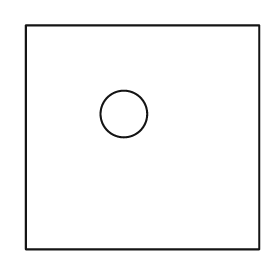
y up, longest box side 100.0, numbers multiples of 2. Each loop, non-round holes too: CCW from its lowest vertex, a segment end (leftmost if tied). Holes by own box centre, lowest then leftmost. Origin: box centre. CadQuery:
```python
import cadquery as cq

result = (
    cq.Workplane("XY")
    .moveTo(-50.0, -48.0)
    .lineTo(50.0, -48.0)
    .lineTo(50.0, 48.0)
    .lineTo(-50.0, 48.0)
    .close()
    .moveTo(-8.0, 10.0)
    .circle(10.0)
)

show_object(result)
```